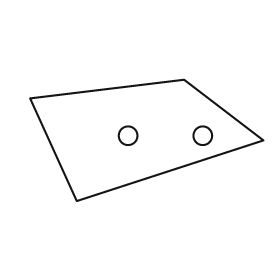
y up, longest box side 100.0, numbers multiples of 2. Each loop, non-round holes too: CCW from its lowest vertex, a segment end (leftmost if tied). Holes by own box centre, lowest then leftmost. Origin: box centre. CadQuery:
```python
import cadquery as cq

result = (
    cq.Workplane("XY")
    .moveTo(-30.0, -26.0)
    .lineTo(50.0, 0.0)
    .lineTo(16.0, 26.0)
    .lineTo(-50.0, 18.0)
    .close()
    .moveTo(-8.0, 2.0)
    .circle(4.0)
    .moveTo(24.0, 2.0)
    .circle(4.0)
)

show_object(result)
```